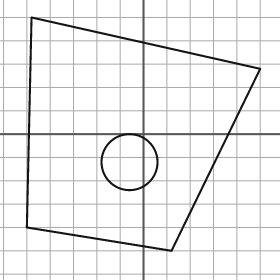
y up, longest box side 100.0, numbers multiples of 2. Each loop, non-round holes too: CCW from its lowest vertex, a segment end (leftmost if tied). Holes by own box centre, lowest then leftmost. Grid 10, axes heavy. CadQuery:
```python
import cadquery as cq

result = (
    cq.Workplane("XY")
    .moveTo(12.0, -50.0)
    .lineTo(50.0, 28.0)
    .lineTo(-48.0, 50.0)
    .lineTo(-50.0, -40.0)
    .close()
    .moveTo(-6.0, -12.0)
    .circle(12.0)
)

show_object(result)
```